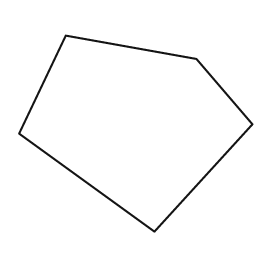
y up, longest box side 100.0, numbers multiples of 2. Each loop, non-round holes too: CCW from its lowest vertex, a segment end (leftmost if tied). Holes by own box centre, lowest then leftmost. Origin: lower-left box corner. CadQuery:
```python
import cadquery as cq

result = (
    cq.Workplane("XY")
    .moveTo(58.0, 0.0)
    .lineTo(100.0, 46.0)
    .lineTo(76.0, 74.0)
    .lineTo(20.0, 84.0)
    .lineTo(0.0, 42.0)
    .close()
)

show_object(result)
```